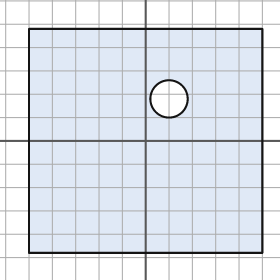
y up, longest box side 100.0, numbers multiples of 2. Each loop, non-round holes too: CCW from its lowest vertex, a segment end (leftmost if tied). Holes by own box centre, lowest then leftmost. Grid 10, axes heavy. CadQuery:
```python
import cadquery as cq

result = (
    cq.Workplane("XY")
    .moveTo(-50.0, -48.0)
    .lineTo(50.0, -48.0)
    .lineTo(50.0, 48.0)
    .lineTo(-50.0, 48.0)
    .close()
    .moveTo(10.0, 18.0)
    .circle(8.0)
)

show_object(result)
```